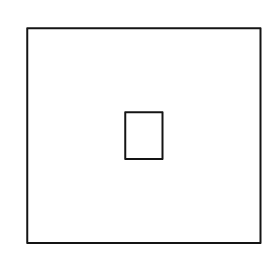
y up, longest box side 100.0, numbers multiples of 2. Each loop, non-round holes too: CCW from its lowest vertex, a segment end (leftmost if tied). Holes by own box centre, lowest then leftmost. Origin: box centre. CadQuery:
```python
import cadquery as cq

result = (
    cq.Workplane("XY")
    .moveTo(-50.0, -46.0)
    .lineTo(50.0, -46.0)
    .lineTo(50.0, 46.0)
    .lineTo(-50.0, 46.0)
    .close()
    .moveTo(-8.0, -10.0)
    .lineTo(8.0, -10.0)
    .lineTo(8.0, 10.0)
    .lineTo(-8.0, 10.0)
    .close()
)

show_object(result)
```